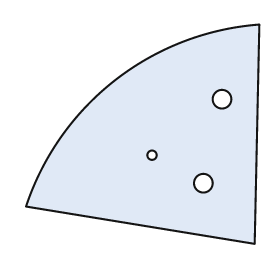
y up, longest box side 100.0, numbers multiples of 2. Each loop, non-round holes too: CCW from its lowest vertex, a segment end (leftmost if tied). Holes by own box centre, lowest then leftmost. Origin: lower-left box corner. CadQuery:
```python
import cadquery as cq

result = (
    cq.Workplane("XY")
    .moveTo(98.0, 0.0)
    .lineTo(100.0, 94.0)
    .threePointArc((38.0, 70.0), (0.0, 16.0))
    .close()
    .moveTo(76.0, 26.0)
    .circle(4.0)
    .moveTo(54.0, 38.0)
    .circle(2.0)
    .moveTo(84.0, 62.0)
    .circle(4.0)
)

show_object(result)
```